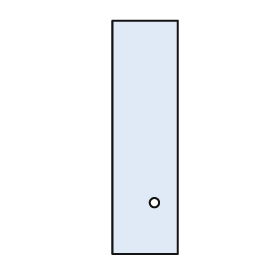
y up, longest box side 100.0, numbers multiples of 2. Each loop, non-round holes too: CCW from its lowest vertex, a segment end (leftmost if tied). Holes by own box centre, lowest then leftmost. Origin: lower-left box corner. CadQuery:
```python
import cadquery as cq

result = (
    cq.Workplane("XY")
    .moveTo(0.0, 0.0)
    .lineTo(28.0, 0.0)
    .lineTo(28.0, 100.0)
    .lineTo(0.0, 100.0)
    .close()
    .moveTo(18.0, 22.0)
    .circle(2.0)
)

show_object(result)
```